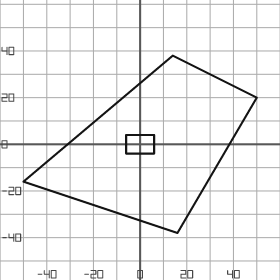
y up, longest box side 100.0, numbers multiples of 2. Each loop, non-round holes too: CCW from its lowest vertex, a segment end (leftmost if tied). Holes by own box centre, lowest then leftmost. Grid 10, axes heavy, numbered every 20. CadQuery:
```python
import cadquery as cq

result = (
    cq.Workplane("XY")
    .moveTo(16.0, -38.0)
    .lineTo(50.0, 20.0)
    .lineTo(14.0, 38.0)
    .lineTo(-50.0, -16.0)
    .close()
    .moveTo(-6.0, -4.0)
    .lineTo(6.0, -4.0)
    .lineTo(6.0, 4.0)
    .lineTo(-6.0, 4.0)
    .close()
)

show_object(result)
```